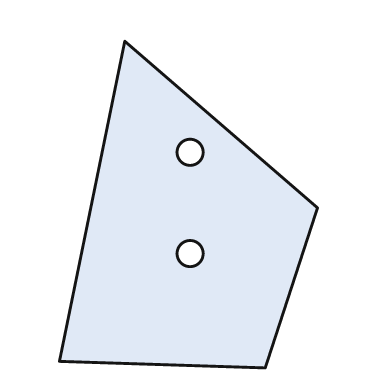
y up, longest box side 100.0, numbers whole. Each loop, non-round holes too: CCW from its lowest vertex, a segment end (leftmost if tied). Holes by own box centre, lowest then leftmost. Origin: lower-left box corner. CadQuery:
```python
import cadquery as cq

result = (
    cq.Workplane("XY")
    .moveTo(63.0, 0.0)
    .lineTo(79.0, 49.0)
    .lineTo(20.0, 100.0)
    .lineTo(0.0, 2.0)
    .close()
    .moveTo(40.0, 35.0)
    .circle(4.0)
    .moveTo(40.0, 66.0)
    .circle(4.0)
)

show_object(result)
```